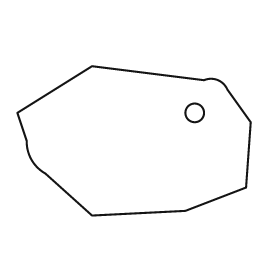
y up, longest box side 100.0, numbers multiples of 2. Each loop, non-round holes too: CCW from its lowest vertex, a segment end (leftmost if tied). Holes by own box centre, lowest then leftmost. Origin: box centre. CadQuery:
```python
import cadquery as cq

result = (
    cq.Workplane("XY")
    .moveTo(-18.0, -32.0)
    .lineTo(22.0, -30.0)
    .lineTo(48.0, -20.0)
    .lineTo(50.0, 8.0)
    .lineTo(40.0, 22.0)
    .threePointArc((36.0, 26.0), (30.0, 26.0))
    .lineTo(-18.0, 32.0)
    .lineTo(-50.0, 12.0)
    .lineTo(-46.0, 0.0)
    .threePointArc((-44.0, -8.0), (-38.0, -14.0))
    .close()
    .moveTo(26.0, 12.0)
    .circle(4.0)
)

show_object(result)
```